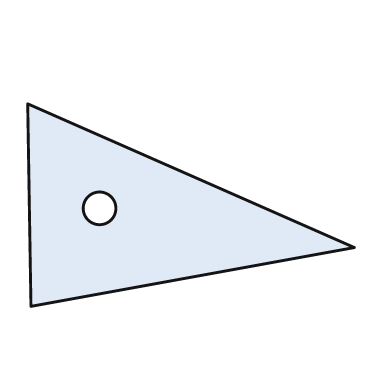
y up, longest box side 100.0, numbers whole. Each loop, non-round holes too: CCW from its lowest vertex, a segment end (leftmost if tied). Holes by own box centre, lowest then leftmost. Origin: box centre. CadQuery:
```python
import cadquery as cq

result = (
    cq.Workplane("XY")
    .moveTo(-49.0, -31.0)
    .lineTo(50.0, -13.0)
    .lineTo(-50.0, 31.0)
    .close()
    .moveTo(-28.0, -1.0)
    .circle(5.0)
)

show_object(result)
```